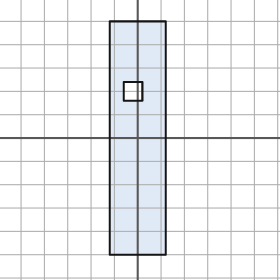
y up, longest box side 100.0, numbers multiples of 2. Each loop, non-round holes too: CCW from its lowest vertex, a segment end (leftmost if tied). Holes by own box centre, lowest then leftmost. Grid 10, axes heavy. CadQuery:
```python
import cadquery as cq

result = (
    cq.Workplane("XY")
    .moveTo(-12.0, -50.0)
    .lineTo(12.0, -50.0)
    .lineTo(12.0, 50.0)
    .lineTo(-12.0, 50.0)
    .close()
    .moveTo(-6.0, 16.0)
    .lineTo(2.0, 16.0)
    .lineTo(2.0, 24.0)
    .lineTo(-6.0, 24.0)
    .close()
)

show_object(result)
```